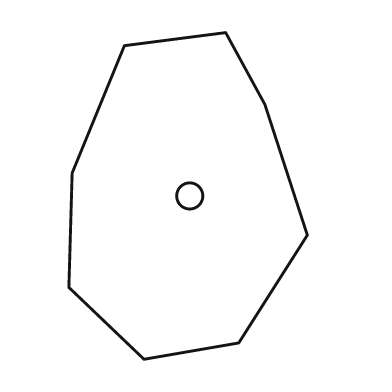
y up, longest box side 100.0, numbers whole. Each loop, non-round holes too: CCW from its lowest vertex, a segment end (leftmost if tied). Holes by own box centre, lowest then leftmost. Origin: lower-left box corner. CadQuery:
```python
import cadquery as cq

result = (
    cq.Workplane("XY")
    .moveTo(23.0, 0.0)
    .lineTo(52.0, 5.0)
    .lineTo(73.0, 38.0)
    .lineTo(60.0, 78.0)
    .lineTo(48.0, 100.0)
    .lineTo(17.0, 96.0)
    .lineTo(1.0, 57.0)
    .lineTo(0.0, 22.0)
    .close()
    .moveTo(37.0, 50.0)
    .circle(4.0)
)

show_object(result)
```